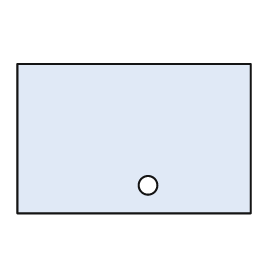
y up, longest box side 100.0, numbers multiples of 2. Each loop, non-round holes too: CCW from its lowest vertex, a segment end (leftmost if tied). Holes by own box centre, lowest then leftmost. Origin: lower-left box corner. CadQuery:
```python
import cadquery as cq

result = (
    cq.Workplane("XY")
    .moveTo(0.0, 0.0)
    .lineTo(100.0, 0.0)
    .lineTo(100.0, 64.0)
    .lineTo(0.0, 64.0)
    .close()
    .moveTo(56.0, 12.0)
    .circle(4.0)
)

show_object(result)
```